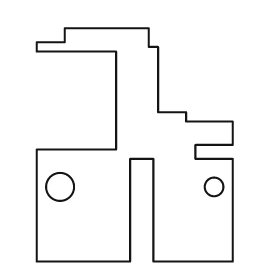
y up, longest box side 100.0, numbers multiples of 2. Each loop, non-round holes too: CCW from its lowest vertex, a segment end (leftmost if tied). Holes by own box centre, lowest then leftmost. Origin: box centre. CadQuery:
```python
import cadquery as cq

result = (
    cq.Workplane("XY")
    .moveTo(-42.0, -50.0)
    .lineTo(-2.0, -50.0)
    .lineTo(-2.0, -6.0)
    .lineTo(8.0, -6.0)
    .lineTo(8.0, -50.0)
    .lineTo(42.0, -50.0)
    .lineTo(42.0, -6.0)
    .lineTo(26.0, -6.0)
    .lineTo(26.0, 0.0)
    .lineTo(42.0, 0.0)
    .lineTo(42.0, 10.0)
    .lineTo(22.0, 10.0)
    .lineTo(22.0, 14.0)
    .lineTo(10.0, 14.0)
    .lineTo(10.0, 42.0)
    .lineTo(6.0, 42.0)
    .lineTo(6.0, 50.0)
    .lineTo(-30.0, 50.0)
    .lineTo(-30.0, 44.0)
    .lineTo(-42.0, 44.0)
    .lineTo(-42.0, 40.0)
    .lineTo(-8.0, 40.0)
    .lineTo(-8.0, -2.0)
    .lineTo(-42.0, -2.0)
    .close()
    .moveTo(-32.0, -18.0)
    .circle(6.0)
    .moveTo(34.0, -18.0)
    .circle(4.0)
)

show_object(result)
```